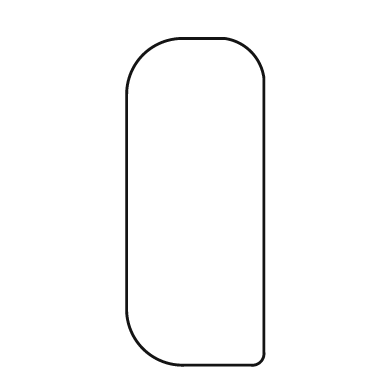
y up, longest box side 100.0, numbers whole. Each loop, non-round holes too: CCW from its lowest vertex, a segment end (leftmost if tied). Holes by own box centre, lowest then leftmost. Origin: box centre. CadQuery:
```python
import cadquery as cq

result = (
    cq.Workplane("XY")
    .moveTo(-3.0, -50.0)
    .lineTo(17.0, -50.0)
    .threePointArc((20.0, -49.0), (21.0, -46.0))
    .lineTo(21.0, 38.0)
    .threePointArc((17.0, 46.0), (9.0, 50.0))
    .lineTo(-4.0, 50.0)
    .threePointArc((-16.0, 45.0), (-21.0, 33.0))
    .lineTo(-21.0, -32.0)
    .threePointArc((-16.0, -45.0), (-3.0, -50.0))
    .close()
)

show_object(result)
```